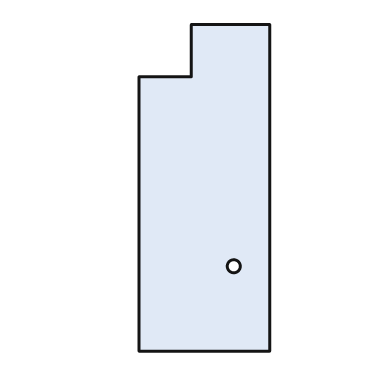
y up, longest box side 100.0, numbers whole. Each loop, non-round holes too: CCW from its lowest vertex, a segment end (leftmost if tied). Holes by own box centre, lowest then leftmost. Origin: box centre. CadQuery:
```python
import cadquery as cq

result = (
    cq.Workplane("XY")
    .moveTo(-20.0, -50.0)
    .lineTo(20.0, -50.0)
    .lineTo(20.0, 50.0)
    .lineTo(-4.0, 50.0)
    .lineTo(-4.0, 34.0)
    .lineTo(-20.0, 34.0)
    .close()
    .moveTo(9.0, -24.0)
    .circle(2.0)
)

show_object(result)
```